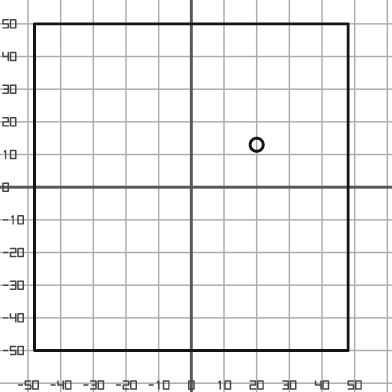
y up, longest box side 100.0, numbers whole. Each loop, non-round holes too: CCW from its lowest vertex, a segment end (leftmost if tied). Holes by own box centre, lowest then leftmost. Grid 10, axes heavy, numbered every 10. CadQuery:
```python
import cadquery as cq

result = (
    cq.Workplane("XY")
    .moveTo(-48.0, -50.0)
    .lineTo(48.0, -50.0)
    .lineTo(48.0, 50.0)
    .lineTo(-48.0, 50.0)
    .close()
    .moveTo(20.0, 13.0)
    .circle(2.0)
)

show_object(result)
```